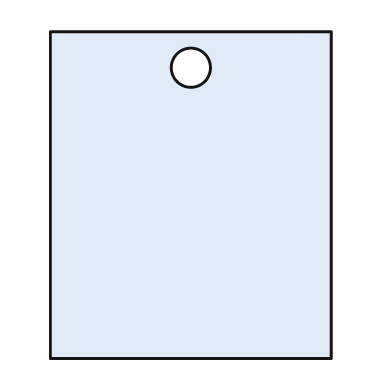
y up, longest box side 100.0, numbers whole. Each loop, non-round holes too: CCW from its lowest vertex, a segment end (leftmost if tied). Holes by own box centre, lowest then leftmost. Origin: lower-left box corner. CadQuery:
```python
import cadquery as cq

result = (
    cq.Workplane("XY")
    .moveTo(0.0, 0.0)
    .lineTo(86.0, 0.0)
    .lineTo(86.0, 100.0)
    .lineTo(0.0, 100.0)
    .close()
    .moveTo(43.0, 89.0)
    .circle(6.0)
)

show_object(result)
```